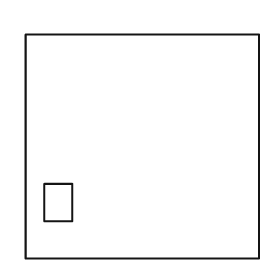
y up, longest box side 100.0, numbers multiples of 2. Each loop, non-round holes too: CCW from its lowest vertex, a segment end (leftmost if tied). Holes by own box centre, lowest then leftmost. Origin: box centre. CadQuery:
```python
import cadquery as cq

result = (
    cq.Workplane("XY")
    .moveTo(-50.0, -48.0)
    .lineTo(50.0, -48.0)
    .lineTo(50.0, 48.0)
    .lineTo(-50.0, 48.0)
    .close()
    .moveTo(-42.0, -32.0)
    .lineTo(-30.0, -32.0)
    .lineTo(-30.0, -16.0)
    .lineTo(-42.0, -16.0)
    .close()
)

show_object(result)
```